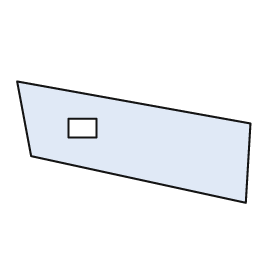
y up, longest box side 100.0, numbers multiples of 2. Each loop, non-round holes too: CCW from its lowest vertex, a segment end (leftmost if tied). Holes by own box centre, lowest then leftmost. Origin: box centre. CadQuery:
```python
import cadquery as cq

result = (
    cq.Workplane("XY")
    .moveTo(48.0, -26.0)
    .lineTo(50.0, 8.0)
    .lineTo(-50.0, 26.0)
    .lineTo(-44.0, -6.0)
    .close()
    .moveTo(-28.0, 2.0)
    .lineTo(-16.0, 2.0)
    .lineTo(-16.0, 10.0)
    .lineTo(-28.0, 10.0)
    .close()
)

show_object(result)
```